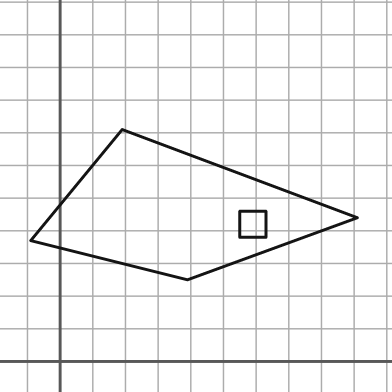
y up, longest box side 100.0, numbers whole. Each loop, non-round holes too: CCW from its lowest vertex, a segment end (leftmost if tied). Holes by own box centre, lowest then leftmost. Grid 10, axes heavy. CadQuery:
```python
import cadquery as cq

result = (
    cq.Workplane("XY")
    .moveTo(39.0, 25.0)
    .lineTo(91.0, 44.0)
    .lineTo(19.0, 71.0)
    .lineTo(-9.0, 37.0)
    .close()
    .moveTo(55.0, 38.0)
    .lineTo(63.0, 38.0)
    .lineTo(63.0, 46.0)
    .lineTo(55.0, 46.0)
    .close()
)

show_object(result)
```